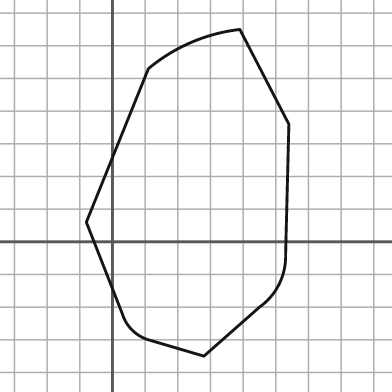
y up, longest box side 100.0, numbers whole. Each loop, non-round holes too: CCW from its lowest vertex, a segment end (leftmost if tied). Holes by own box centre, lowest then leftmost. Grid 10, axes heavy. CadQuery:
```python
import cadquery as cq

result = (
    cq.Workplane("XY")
    .moveTo(28.0, -35.0)
    .lineTo(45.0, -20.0)
    .threePointArc((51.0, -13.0), (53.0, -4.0))
    .lineTo(54.0, 36.0)
    .lineTo(39.0, 65.0)
    .threePointArc((24.0, 61.0), (11.0, 53.0))
    .lineTo(-8.0, 6.0)
    .lineTo(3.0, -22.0)
    .threePointArc((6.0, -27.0), (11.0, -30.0))
    .close()
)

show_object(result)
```